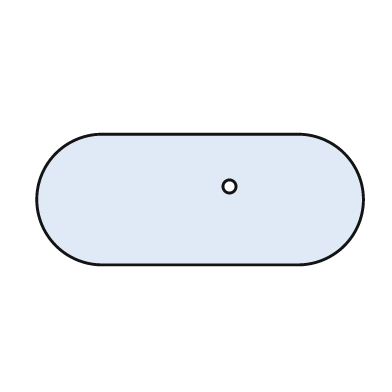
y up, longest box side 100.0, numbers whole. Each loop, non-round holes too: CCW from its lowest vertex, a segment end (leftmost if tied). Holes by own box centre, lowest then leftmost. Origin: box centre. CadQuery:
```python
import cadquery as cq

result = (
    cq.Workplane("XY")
    .moveTo(-30.0, -20.0)
    .lineTo(30.0, -20.0)
    .threePointArc((50.0, 0.0), (30.0, 20.0))
    .lineTo(-30.0, 20.0)
    .threePointArc((-50.0, 0.0), (-30.0, -20.0))
    .close()
    .moveTo(9.0, 4.0)
    .circle(2.0)
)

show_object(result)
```